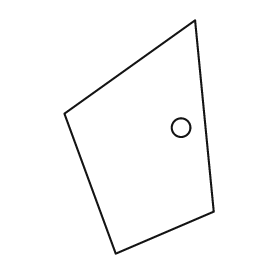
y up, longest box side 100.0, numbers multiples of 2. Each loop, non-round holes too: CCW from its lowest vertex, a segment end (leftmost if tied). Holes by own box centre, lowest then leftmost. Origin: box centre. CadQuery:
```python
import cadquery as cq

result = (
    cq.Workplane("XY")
    .moveTo(-10.0, -50.0)
    .lineTo(32.0, -32.0)
    .lineTo(24.0, 50.0)
    .lineTo(-32.0, 10.0)
    .close()
    .moveTo(18.0, 4.0)
    .circle(4.0)
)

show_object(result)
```